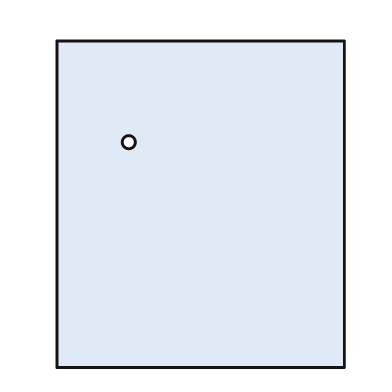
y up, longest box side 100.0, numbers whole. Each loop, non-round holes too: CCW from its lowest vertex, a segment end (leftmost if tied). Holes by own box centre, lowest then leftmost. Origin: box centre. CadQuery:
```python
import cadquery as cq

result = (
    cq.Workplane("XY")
    .moveTo(-44.0, -50.0)
    .lineTo(44.0, -50.0)
    .lineTo(44.0, 50.0)
    .lineTo(-44.0, 50.0)
    .close()
    .moveTo(-22.0, 19.0)
    .circle(2.0)
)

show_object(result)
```